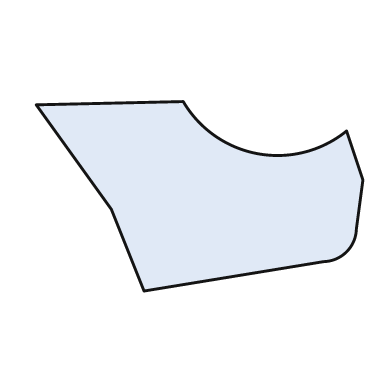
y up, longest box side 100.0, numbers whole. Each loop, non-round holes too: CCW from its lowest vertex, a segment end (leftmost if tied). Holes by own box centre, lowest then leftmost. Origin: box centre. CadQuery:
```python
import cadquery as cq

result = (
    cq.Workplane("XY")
    .moveTo(-17.0, -29.0)
    .lineTo(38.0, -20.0)
    .threePointArc((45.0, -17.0), (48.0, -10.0))
    .lineTo(50.0, 5.0)
    .lineTo(45.0, 20.0)
    .threePointArc((18.0, 13.0), (-5.0, 29.0))
    .lineTo(-50.0, 28.0)
    .lineTo(-27.0, -4.0)
    .close()
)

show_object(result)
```